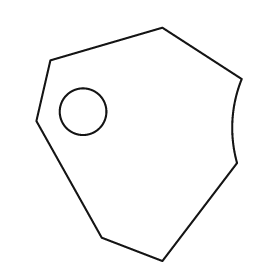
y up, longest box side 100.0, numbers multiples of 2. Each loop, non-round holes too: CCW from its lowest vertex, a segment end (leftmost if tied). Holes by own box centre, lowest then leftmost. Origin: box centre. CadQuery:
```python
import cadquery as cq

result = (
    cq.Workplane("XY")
    .moveTo(10.0, -50.0)
    .lineTo(42.0, -8.0)
    .threePointArc((40.0, 10.0), (44.0, 28.0))
    .lineTo(10.0, 50.0)
    .lineTo(-38.0, 36.0)
    .lineTo(-44.0, 10.0)
    .lineTo(-16.0, -40.0)
    .close()
    .moveTo(-24.0, 14.0)
    .circle(10.0)
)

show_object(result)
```